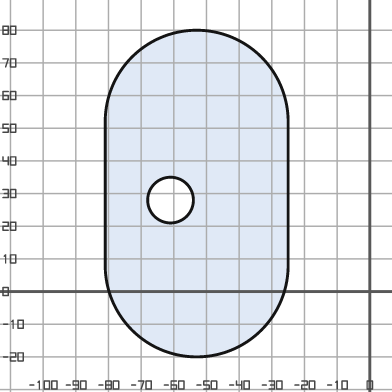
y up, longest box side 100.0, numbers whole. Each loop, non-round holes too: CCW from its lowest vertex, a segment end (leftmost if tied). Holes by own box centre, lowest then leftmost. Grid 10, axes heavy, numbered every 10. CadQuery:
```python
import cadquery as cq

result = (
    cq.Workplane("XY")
    .moveTo(-81.0, 8.0)
    .threePointArc((-53.0, -20.0), (-25.0, 8.0))
    .lineTo(-25.0, 52.0)
    .threePointArc((-53.0, 80.0), (-81.0, 52.0))
    .close()
    .moveTo(-61.0, 28.0)
    .circle(7.0)
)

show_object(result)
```